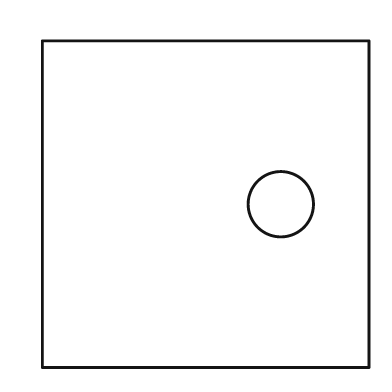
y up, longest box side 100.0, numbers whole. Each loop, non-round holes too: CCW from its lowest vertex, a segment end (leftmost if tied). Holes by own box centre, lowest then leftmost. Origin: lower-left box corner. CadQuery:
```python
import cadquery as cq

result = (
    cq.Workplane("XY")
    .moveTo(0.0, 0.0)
    .lineTo(100.0, 0.0)
    .lineTo(100.0, 100.0)
    .lineTo(0.0, 100.0)
    .close()
    .moveTo(73.0, 50.0)
    .circle(10.0)
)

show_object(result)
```